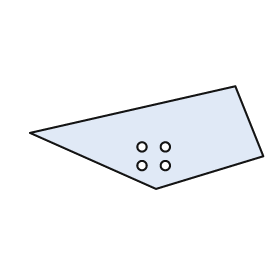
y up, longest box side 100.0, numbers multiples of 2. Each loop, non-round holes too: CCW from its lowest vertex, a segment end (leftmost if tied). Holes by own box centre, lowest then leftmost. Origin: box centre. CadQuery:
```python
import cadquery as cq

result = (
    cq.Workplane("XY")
    .moveTo(4.0, -22.0)
    .lineTo(50.0, -8.0)
    .lineTo(38.0, 22.0)
    .lineTo(-50.0, 2.0)
    .close()
    .moveTo(-2.0, -12.0)
    .circle(2.0)
    .moveTo(8.0, -12.0)
    .circle(2.0)
    .moveTo(-2.0, -4.0)
    .circle(2.0)
    .moveTo(8.0, -4.0)
    .circle(2.0)
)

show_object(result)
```